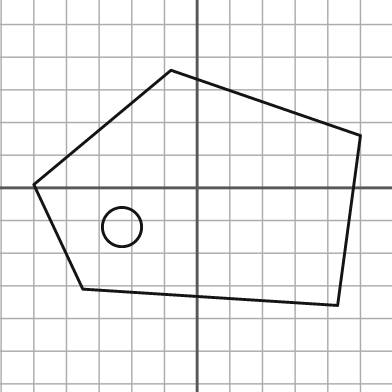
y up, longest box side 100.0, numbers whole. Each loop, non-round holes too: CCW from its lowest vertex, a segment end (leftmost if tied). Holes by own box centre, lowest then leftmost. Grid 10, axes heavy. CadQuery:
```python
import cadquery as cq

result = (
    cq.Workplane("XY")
    .moveTo(43.0, -36.0)
    .lineTo(50.0, 16.0)
    .lineTo(-8.0, 36.0)
    .lineTo(-50.0, 1.0)
    .lineTo(-35.0, -31.0)
    .close()
    .moveTo(-23.0, -12.0)
    .circle(6.0)
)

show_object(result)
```